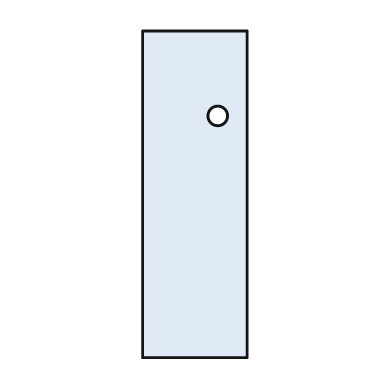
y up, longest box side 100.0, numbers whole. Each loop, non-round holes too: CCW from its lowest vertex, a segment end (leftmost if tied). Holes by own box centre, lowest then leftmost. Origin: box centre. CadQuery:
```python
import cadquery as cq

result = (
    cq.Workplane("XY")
    .moveTo(-16.0, -50.0)
    .lineTo(16.0, -50.0)
    .lineTo(16.0, 50.0)
    .lineTo(-16.0, 50.0)
    .close()
    .moveTo(7.0, 24.0)
    .circle(3.0)
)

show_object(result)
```